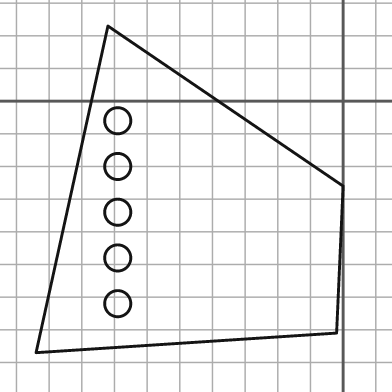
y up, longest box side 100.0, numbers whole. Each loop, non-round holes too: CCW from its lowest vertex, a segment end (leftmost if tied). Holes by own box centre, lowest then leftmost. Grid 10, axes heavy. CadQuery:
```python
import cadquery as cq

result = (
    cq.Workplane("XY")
    .moveTo(-94.0, -77.0)
    .lineTo(-2.0, -71.0)
    .lineTo(0.0, -26.0)
    .lineTo(-72.0, 23.0)
    .close()
    .moveTo(-69.0, -62.0)
    .circle(4.0)
    .moveTo(-69.0, -48.0)
    .circle(4.0)
    .moveTo(-69.0, -34.0)
    .circle(4.0)
    .moveTo(-69.0, -20.0)
    .circle(4.0)
    .moveTo(-69.0, -6.0)
    .circle(4.0)
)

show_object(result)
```